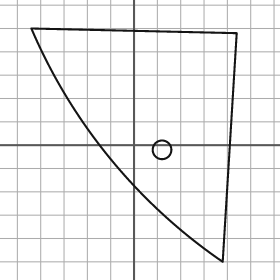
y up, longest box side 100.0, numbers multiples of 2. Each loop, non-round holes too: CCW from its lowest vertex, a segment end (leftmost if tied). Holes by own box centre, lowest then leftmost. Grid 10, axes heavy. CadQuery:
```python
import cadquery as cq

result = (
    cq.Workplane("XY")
    .moveTo(38.0, -50.0)
    .lineTo(44.0, 48.0)
    .lineTo(-44.0, 50.0)
    .threePointArc((-10.0, -6.0), (38.0, -50.0))
    .close()
    .moveTo(12.0, -2.0)
    .circle(4.0)
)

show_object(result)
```